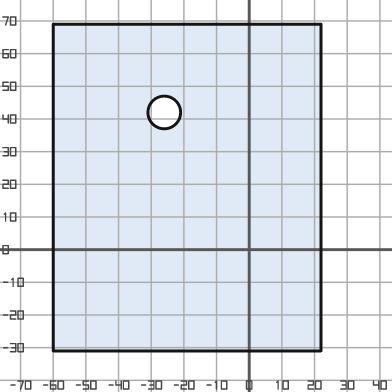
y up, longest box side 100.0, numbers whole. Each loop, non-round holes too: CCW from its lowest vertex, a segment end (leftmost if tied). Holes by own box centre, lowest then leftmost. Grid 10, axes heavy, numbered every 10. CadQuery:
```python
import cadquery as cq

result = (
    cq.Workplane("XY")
    .moveTo(-60.0, -31.0)
    .lineTo(22.0, -31.0)
    .lineTo(22.0, 69.0)
    .lineTo(-60.0, 69.0)
    .close()
    .moveTo(-26.0, 42.0)
    .circle(5.0)
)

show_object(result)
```